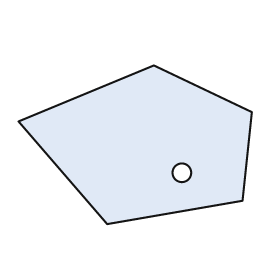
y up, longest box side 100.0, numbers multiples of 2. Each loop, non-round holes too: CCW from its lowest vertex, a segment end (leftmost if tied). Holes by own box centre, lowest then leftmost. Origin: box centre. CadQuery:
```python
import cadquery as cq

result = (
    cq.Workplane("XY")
    .moveTo(-12.0, -34.0)
    .lineTo(46.0, -24.0)
    .lineTo(50.0, 14.0)
    .lineTo(8.0, 34.0)
    .lineTo(-50.0, 10.0)
    .close()
    .moveTo(20.0, -12.0)
    .circle(4.0)
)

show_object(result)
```